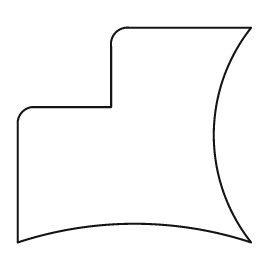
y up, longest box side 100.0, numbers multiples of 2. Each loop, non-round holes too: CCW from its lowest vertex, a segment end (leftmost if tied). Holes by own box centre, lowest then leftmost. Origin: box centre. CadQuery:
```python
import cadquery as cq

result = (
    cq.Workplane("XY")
    .moveTo(-50.0, -46.0)
    .threePointArc((0.0, -38.0), (50.0, -46.0))
    .threePointArc((34.0, 0.0), (50.0, 46.0))
    .lineTo(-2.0, 46.0)
    .threePointArc((-8.0, 44.0), (-10.0, 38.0))
    .lineTo(-10.0, 12.0)
    .lineTo(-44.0, 12.0)
    .threePointArc((-48.0, 10.0), (-50.0, 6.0))
    .close()
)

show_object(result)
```